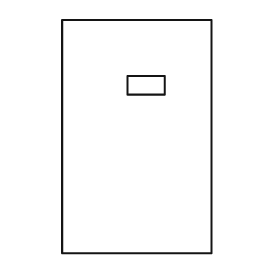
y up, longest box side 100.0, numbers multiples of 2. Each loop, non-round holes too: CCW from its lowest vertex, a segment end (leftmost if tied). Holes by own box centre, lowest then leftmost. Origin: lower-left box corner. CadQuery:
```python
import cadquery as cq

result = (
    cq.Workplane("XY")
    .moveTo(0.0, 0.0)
    .lineTo(64.0, 0.0)
    .lineTo(64.0, 100.0)
    .lineTo(0.0, 100.0)
    .close()
    .moveTo(28.0, 68.0)
    .lineTo(44.0, 68.0)
    .lineTo(44.0, 76.0)
    .lineTo(28.0, 76.0)
    .close()
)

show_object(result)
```